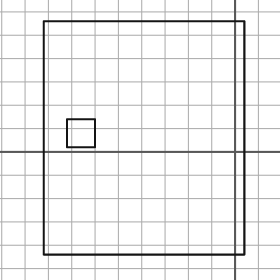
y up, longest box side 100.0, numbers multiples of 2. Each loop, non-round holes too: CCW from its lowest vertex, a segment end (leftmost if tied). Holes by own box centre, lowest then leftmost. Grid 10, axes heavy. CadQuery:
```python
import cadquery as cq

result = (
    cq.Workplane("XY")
    .moveTo(-82.0, -44.0)
    .lineTo(4.0, -44.0)
    .lineTo(4.0, 56.0)
    .lineTo(-82.0, 56.0)
    .close()
    .moveTo(-72.0, 2.0)
    .lineTo(-60.0, 2.0)
    .lineTo(-60.0, 14.0)
    .lineTo(-72.0, 14.0)
    .close()
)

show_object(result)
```